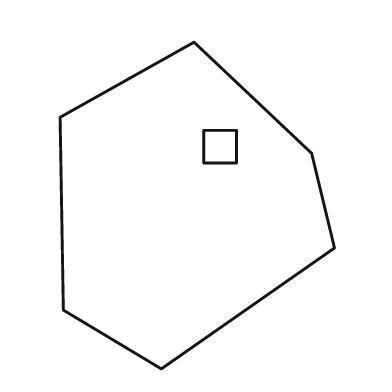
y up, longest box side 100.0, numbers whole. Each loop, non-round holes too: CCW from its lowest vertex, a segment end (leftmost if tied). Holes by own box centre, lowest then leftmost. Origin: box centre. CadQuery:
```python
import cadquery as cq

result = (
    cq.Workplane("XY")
    .moveTo(-11.0, -50.0)
    .lineTo(42.0, -13.0)
    .lineTo(35.0, 16.0)
    .lineTo(-1.0, 50.0)
    .lineTo(-42.0, 27.0)
    .lineTo(-41.0, -32.0)
    .close()
    .moveTo(2.0, 13.0)
    .lineTo(12.0, 13.0)
    .lineTo(12.0, 23.0)
    .lineTo(2.0, 23.0)
    .close()
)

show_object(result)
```